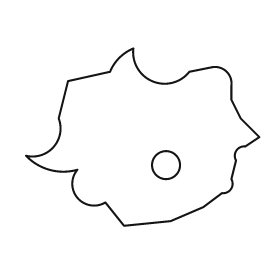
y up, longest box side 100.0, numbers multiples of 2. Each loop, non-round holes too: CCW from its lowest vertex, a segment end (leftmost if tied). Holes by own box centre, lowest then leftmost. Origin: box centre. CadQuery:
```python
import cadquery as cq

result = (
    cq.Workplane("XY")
    .moveTo(-8.0, -38.0)
    .lineTo(12.0, -36.0)
    .lineTo(26.0, -30.0)
    .lineTo(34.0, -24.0)
    .threePointArc((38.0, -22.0), (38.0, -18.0))
    .lineTo(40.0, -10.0)
    .threePointArc((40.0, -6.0), (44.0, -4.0))
    .lineTo(50.0, 0.0)
    .lineTo(42.0, 8.0)
    .lineTo(38.0, 16.0)
    .lineTo(38.0, 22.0)
    .threePointArc((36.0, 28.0), (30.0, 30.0))
    .lineTo(20.0, 28.0)
    .threePointArc((4.0, 24.0), (-4.0, 38.0))
    .threePointArc((-10.0, 34.0), (-14.0, 28.0))
    .lineTo(-32.0, 24.0)
    .lineTo(-36.0, 8.0)
    .threePointArc((-38.0, -4.0), (-50.0, -8.0))
    .threePointArc((-40.0, -14.0), (-28.0, -14.0))
    .threePointArc((-28.0, -26.0), (-16.0, -28.0))
    .close()
    .moveTo(10.0, -12.0)
    .circle(6.0)
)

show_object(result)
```